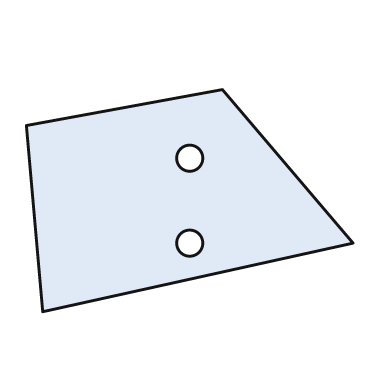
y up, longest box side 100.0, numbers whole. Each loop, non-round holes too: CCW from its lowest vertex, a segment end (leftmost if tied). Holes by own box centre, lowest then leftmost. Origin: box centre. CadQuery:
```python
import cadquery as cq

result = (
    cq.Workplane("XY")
    .moveTo(-45.0, -34.0)
    .lineTo(50.0, -13.0)
    .lineTo(10.0, 34.0)
    .lineTo(-50.0, 23.0)
    .close()
    .moveTo(0.0, -13.0)
    .circle(4.0)
    .moveTo(0.0, 13.0)
    .circle(4.0)
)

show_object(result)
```